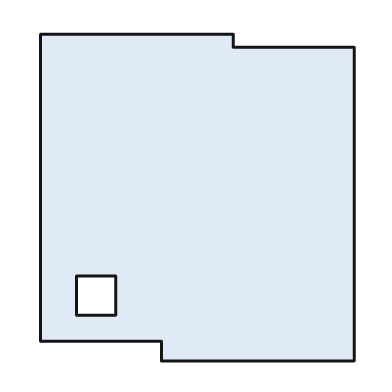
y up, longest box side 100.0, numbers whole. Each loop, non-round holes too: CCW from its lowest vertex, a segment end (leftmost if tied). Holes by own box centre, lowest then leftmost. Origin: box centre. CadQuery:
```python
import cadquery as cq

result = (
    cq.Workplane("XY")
    .moveTo(-11.0, -50.0)
    .lineTo(48.0, -50.0)
    .lineTo(48.0, 46.0)
    .lineTo(11.0, 46.0)
    .lineTo(11.0, 50.0)
    .lineTo(-48.0, 50.0)
    .lineTo(-48.0, -44.0)
    .lineTo(-11.0, -44.0)
    .close()
    .moveTo(-37.0, -36.0)
    .lineTo(-25.0, -36.0)
    .lineTo(-25.0, -24.0)
    .lineTo(-37.0, -24.0)
    .close()
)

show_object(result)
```